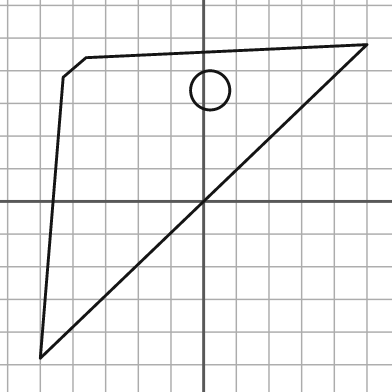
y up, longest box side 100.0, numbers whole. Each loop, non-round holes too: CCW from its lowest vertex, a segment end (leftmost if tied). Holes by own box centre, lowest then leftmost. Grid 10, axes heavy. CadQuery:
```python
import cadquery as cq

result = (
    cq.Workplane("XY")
    .moveTo(-50.0, -48.0)
    .lineTo(50.0, 48.0)
    .lineTo(-36.0, 44.0)
    .lineTo(-43.0, 38.0)
    .close()
    .moveTo(2.0, 34.0)
    .circle(6.0)
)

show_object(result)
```